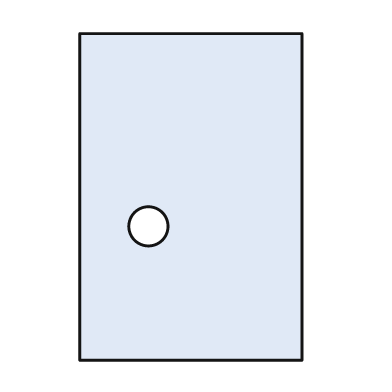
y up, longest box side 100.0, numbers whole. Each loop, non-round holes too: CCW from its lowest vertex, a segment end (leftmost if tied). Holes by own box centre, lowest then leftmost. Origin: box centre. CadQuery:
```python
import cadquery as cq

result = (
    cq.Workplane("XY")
    .moveTo(-34.0, -50.0)
    .lineTo(34.0, -50.0)
    .lineTo(34.0, 50.0)
    .lineTo(-34.0, 50.0)
    .close()
    .moveTo(-13.0, -9.0)
    .circle(6.0)
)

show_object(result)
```